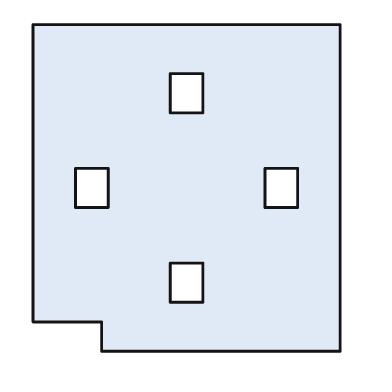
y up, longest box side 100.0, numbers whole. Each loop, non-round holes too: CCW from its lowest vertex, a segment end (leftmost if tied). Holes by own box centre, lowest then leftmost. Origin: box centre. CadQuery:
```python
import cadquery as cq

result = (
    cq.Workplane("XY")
    .moveTo(-26.0, -50.0)
    .lineTo(47.0, -50.0)
    .lineTo(47.0, 50.0)
    .lineTo(-47.0, 50.0)
    .lineTo(-47.0, -41.0)
    .lineTo(-26.0, -41.0)
    .close()
    .moveTo(-5.0, -35.0)
    .lineTo(5.0, -35.0)
    .lineTo(5.0, -23.0)
    .lineTo(-5.0, -23.0)
    .close()
    .moveTo(-34.0, -6.0)
    .lineTo(-24.0, -6.0)
    .lineTo(-24.0, 6.0)
    .lineTo(-34.0, 6.0)
    .close()
    .moveTo(24.0, -6.0)
    .lineTo(34.0, -6.0)
    .lineTo(34.0, 6.0)
    .lineTo(24.0, 6.0)
    .close()
    .moveTo(-5.0, 23.0)
    .lineTo(5.0, 23.0)
    .lineTo(5.0, 35.0)
    .lineTo(-5.0, 35.0)
    .close()
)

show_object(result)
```